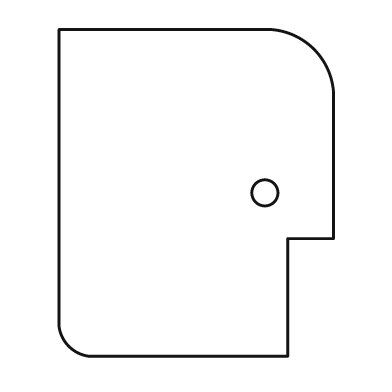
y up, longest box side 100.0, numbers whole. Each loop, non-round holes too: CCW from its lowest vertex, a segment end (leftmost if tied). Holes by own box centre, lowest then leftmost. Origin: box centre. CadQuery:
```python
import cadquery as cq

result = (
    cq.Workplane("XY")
    .moveTo(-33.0, -50.0)
    .lineTo(28.0, -50.0)
    .lineTo(28.0, -14.0)
    .lineTo(42.0, -14.0)
    .lineTo(42.0, 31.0)
    .threePointArc((36.0, 44.0), (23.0, 50.0))
    .lineTo(-42.0, 50.0)
    .lineTo(-42.0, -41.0)
    .threePointArc((-39.0, -47.0), (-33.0, -50.0))
    .close()
    .moveTo(21.0, 0.0)
    .circle(4.0)
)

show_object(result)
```